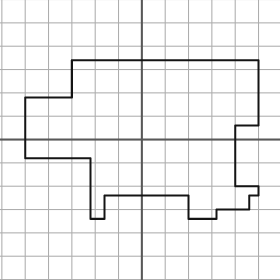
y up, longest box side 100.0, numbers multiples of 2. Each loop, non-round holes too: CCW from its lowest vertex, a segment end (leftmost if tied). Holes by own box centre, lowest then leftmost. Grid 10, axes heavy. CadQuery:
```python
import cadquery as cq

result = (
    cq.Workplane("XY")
    .moveTo(-22.0, -34.0)
    .lineTo(-16.0, -34.0)
    .lineTo(-16.0, -24.0)
    .lineTo(20.0, -24.0)
    .lineTo(20.0, -34.0)
    .lineTo(32.0, -34.0)
    .lineTo(32.0, -30.0)
    .lineTo(46.0, -30.0)
    .lineTo(46.0, -24.0)
    .lineTo(50.0, -24.0)
    .lineTo(50.0, -20.0)
    .lineTo(40.0, -20.0)
    .lineTo(40.0, 6.0)
    .lineTo(50.0, 6.0)
    .lineTo(50.0, 34.0)
    .lineTo(-30.0, 34.0)
    .lineTo(-30.0, 18.0)
    .lineTo(-50.0, 18.0)
    .lineTo(-50.0, -8.0)
    .lineTo(-22.0, -8.0)
    .close()
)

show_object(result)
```